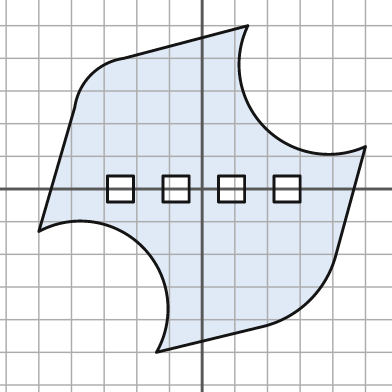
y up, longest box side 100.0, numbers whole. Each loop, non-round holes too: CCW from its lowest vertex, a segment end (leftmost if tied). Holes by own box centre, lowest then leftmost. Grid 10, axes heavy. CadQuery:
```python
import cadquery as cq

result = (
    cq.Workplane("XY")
    .moveTo(-14.0, -50.0)
    .lineTo(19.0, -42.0)
    .threePointArc((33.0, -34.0), (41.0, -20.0))
    .lineTo(50.0, 13.0)
    .threePointArc((19.0, 19.0), (14.0, 50.0))
    .lineTo(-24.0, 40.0)
    .threePointArc((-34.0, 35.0), (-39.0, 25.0))
    .lineTo(-50.0, -13.0)
    .threePointArc((-18.0, -18.0), (-14.0, -50.0))
    .close()
    .moveTo(-29.0, -4.0)
    .lineTo(-21.0, -4.0)
    .lineTo(-21.0, 4.0)
    .lineTo(-29.0, 4.0)
    .close()
    .moveTo(-12.0, -4.0)
    .lineTo(-4.0, -4.0)
    .lineTo(-4.0, 4.0)
    .lineTo(-12.0, 4.0)
    .close()
    .moveTo(5.0, -4.0)
    .lineTo(13.0, -4.0)
    .lineTo(13.0, 4.0)
    .lineTo(5.0, 4.0)
    .close()
    .moveTo(22.0, -4.0)
    .lineTo(30.0, -4.0)
    .lineTo(30.0, 4.0)
    .lineTo(22.0, 4.0)
    .close()
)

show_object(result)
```